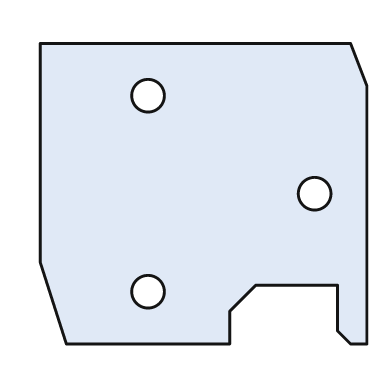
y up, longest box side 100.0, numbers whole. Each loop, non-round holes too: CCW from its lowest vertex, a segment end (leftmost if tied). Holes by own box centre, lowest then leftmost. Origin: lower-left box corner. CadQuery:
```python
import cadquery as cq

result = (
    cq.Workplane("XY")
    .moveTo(8.0, 0.0)
    .lineTo(58.0, 0.0)
    .lineTo(58.0, 10.0)
    .lineTo(66.0, 18.0)
    .lineTo(91.0, 18.0)
    .lineTo(91.0, 4.0)
    .lineTo(95.0, 0.0)
    .lineTo(100.0, 0.0)
    .lineTo(100.0, 79.0)
    .lineTo(95.0, 92.0)
    .lineTo(0.0, 92.0)
    .lineTo(0.0, 25.0)
    .close()
    .moveTo(33.0, 16.0)
    .circle(5.0)
    .moveTo(84.0, 46.0)
    .circle(5.0)
    .moveTo(33.0, 76.0)
    .circle(5.0)
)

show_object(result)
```